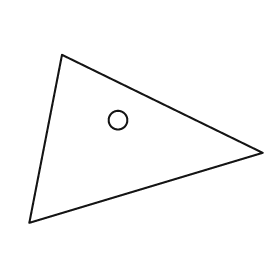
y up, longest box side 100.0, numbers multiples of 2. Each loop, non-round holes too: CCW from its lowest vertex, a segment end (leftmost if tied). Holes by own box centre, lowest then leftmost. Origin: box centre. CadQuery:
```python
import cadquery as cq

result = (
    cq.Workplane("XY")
    .moveTo(-50.0, -36.0)
    .lineTo(50.0, -6.0)
    .lineTo(-36.0, 36.0)
    .close()
    .moveTo(-12.0, 8.0)
    .circle(4.0)
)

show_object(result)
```